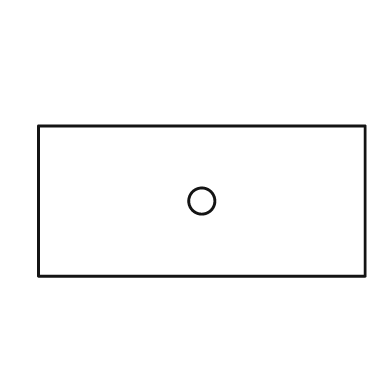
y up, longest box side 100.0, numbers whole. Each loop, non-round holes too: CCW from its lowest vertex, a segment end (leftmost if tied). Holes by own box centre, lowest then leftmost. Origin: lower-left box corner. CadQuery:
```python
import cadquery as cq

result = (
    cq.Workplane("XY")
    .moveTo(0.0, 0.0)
    .lineTo(100.0, 0.0)
    .lineTo(100.0, 46.0)
    .lineTo(0.0, 46.0)
    .close()
    .moveTo(50.0, 23.0)
    .circle(4.0)
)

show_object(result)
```